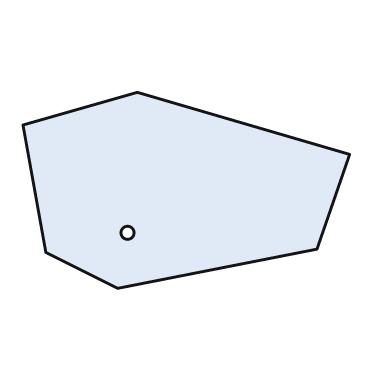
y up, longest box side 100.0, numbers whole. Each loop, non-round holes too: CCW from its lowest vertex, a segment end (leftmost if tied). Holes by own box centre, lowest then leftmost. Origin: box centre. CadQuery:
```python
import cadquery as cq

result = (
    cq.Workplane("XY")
    .moveTo(-21.0, -30.0)
    .lineTo(40.0, -18.0)
    .lineTo(50.0, 11.0)
    .lineTo(-15.0, 30.0)
    .lineTo(-50.0, 20.0)
    .lineTo(-43.0, -19.0)
    .close()
    .moveTo(-18.0, -13.0)
    .circle(2.0)
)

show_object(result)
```